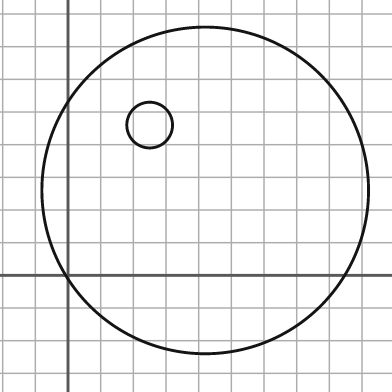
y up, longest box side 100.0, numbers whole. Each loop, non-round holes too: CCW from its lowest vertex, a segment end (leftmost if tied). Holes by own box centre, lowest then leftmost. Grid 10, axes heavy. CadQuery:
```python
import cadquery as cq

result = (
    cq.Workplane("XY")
    .moveTo(42.0, 26.0)
    .circle(50.0)
    .moveTo(25.0, 46.0)
    .circle(7.0)
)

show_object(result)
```